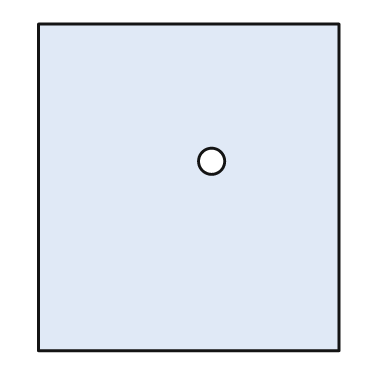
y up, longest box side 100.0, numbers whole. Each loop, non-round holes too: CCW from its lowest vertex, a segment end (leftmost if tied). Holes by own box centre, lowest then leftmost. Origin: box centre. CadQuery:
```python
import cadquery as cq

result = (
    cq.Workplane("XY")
    .moveTo(-46.0, -50.0)
    .lineTo(46.0, -50.0)
    .lineTo(46.0, 50.0)
    .lineTo(-46.0, 50.0)
    .close()
    .moveTo(7.0, 8.0)
    .circle(4.0)
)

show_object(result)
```